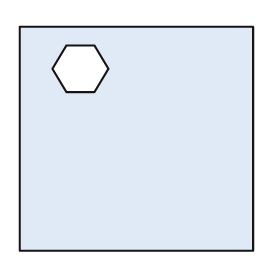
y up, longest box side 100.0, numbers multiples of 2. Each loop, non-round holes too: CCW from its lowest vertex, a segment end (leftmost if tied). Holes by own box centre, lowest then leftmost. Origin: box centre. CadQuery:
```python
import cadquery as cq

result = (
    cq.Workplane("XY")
    .moveTo(-50.0, -48.0)
    .lineTo(50.0, -48.0)
    .lineTo(50.0, 48.0)
    .lineTo(-50.0, 48.0)
    .close()
    .moveTo(-30.0, 20.0)
    .lineTo(-18.0, 20.0)
    .lineTo(-12.0, 30.0)
    .lineTo(-18.0, 40.0)
    .lineTo(-30.0, 40.0)
    .lineTo(-36.0, 30.0)
    .close()
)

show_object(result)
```